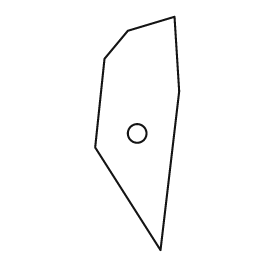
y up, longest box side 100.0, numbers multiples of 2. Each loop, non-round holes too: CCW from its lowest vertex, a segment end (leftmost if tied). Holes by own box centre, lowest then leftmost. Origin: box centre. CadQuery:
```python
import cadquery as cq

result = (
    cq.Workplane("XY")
    .moveTo(10.0, -50.0)
    .lineTo(18.0, 18.0)
    .lineTo(16.0, 50.0)
    .lineTo(-4.0, 44.0)
    .lineTo(-14.0, 32.0)
    .lineTo(-18.0, -6.0)
    .close()
    .moveTo(0.0, 0.0)
    .circle(4.0)
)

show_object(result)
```